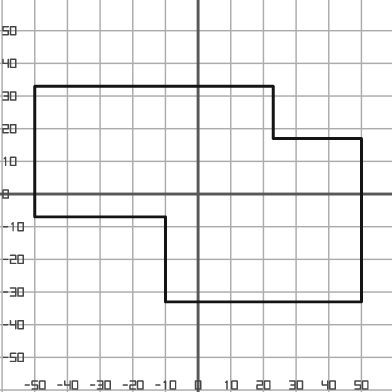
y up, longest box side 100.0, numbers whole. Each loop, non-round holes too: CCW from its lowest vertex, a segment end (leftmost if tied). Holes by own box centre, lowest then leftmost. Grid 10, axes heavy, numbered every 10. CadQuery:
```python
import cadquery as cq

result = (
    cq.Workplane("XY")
    .moveTo(-10.0, -33.0)
    .lineTo(50.0, -33.0)
    .lineTo(50.0, 17.0)
    .lineTo(23.0, 17.0)
    .lineTo(23.0, 33.0)
    .lineTo(-50.0, 33.0)
    .lineTo(-50.0, -7.0)
    .lineTo(-10.0, -7.0)
    .close()
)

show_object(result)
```